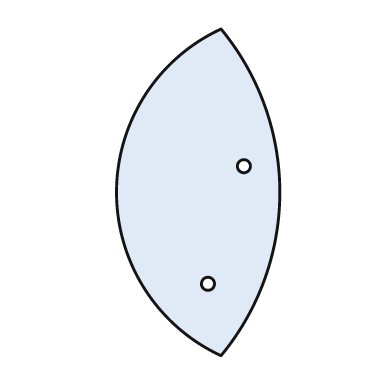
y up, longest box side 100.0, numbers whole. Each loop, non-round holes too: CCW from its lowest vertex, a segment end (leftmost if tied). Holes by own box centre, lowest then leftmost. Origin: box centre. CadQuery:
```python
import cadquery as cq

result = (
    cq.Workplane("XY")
    .moveTo(7.0, -50.0)
    .threePointArc((25.0, 0.0), (7.0, 50.0))
    .threePointArc((-25.0, 0.0), (7.0, -50.0))
    .close()
    .moveTo(3.0, -28.0)
    .circle(2.0)
    .moveTo(14.0, 8.0)
    .circle(2.0)
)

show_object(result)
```